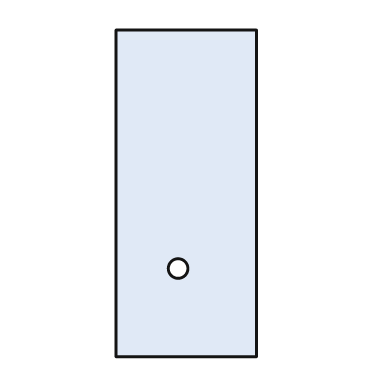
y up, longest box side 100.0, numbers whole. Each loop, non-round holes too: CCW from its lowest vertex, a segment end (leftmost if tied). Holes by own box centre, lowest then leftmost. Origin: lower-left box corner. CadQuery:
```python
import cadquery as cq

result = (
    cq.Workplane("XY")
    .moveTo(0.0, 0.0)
    .lineTo(43.0, 0.0)
    .lineTo(43.0, 100.0)
    .lineTo(0.0, 100.0)
    .close()
    .moveTo(19.0, 27.0)
    .circle(3.0)
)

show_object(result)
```